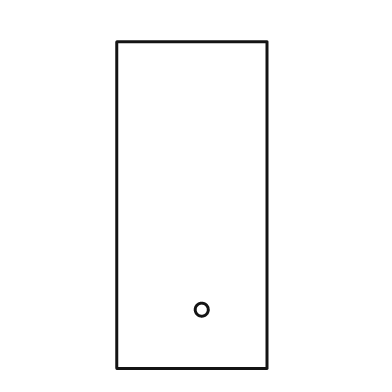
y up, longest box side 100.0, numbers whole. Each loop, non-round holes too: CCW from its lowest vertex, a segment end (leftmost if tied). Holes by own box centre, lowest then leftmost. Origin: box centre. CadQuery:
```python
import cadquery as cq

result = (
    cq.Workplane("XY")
    .moveTo(-23.0, -50.0)
    .lineTo(23.0, -50.0)
    .lineTo(23.0, 50.0)
    .lineTo(-23.0, 50.0)
    .close()
    .moveTo(3.0, -32.0)
    .circle(2.0)
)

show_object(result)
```